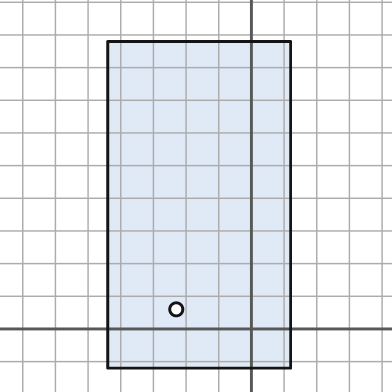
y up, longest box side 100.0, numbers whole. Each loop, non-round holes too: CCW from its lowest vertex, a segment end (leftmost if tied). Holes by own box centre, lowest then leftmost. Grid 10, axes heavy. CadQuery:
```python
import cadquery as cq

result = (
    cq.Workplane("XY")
    .moveTo(-44.0, -12.0)
    .lineTo(12.0, -12.0)
    .lineTo(12.0, 88.0)
    .lineTo(-44.0, 88.0)
    .close()
    .moveTo(-23.0, 6.0)
    .circle(2.0)
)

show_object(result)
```